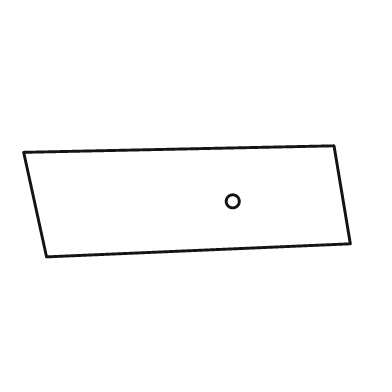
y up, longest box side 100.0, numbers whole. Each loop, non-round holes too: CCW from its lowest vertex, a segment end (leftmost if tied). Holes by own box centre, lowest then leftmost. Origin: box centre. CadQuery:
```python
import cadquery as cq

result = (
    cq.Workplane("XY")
    .moveTo(-43.0, -17.0)
    .lineTo(50.0, -13.0)
    .lineTo(45.0, 17.0)
    .lineTo(-50.0, 15.0)
    .close()
    .moveTo(14.0, 0.0)
    .circle(2.0)
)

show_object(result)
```